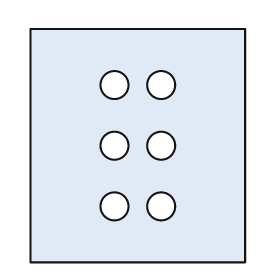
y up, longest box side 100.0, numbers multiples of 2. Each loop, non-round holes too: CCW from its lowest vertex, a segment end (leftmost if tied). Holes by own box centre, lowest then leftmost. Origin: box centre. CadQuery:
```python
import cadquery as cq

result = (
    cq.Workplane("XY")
    .moveTo(-46.0, -50.0)
    .lineTo(46.0, -50.0)
    .lineTo(46.0, 50.0)
    .lineTo(-46.0, 50.0)
    .close()
    .moveTo(-10.0, -26.0)
    .circle(6.0)
    .moveTo(10.0, -26.0)
    .circle(6.0)
    .moveTo(-10.0, 0.0)
    .circle(6.0)
    .moveTo(10.0, 0.0)
    .circle(6.0)
    .moveTo(-10.0, 26.0)
    .circle(6.0)
    .moveTo(10.0, 26.0)
    .circle(6.0)
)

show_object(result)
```